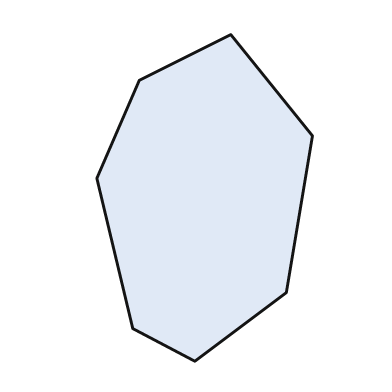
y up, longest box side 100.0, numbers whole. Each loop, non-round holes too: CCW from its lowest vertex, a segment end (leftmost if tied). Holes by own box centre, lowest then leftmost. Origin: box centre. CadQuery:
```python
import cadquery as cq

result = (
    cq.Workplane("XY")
    .moveTo(-3.0, -50.0)
    .lineTo(25.0, -29.0)
    .lineTo(33.0, 19.0)
    .lineTo(8.0, 50.0)
    .lineTo(-20.0, 36.0)
    .lineTo(-33.0, 6.0)
    .lineTo(-22.0, -40.0)
    .close()
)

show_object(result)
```